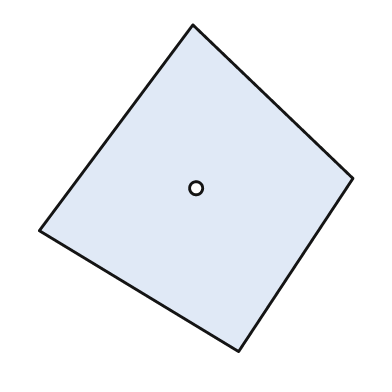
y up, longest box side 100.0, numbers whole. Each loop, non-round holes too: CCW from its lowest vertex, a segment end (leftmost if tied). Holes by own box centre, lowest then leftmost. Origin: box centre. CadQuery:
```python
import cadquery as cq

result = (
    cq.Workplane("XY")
    .moveTo(13.0, -50.0)
    .lineTo(48.0, 3.0)
    .lineTo(-1.0, 50.0)
    .lineTo(-48.0, -13.0)
    .close()
    .moveTo(0.0, 0.0)
    .circle(2.0)
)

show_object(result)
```